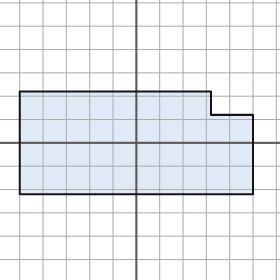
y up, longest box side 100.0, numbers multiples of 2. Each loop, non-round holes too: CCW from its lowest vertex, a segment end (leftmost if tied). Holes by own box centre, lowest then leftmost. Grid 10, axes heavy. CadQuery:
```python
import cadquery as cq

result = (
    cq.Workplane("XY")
    .moveTo(-50.0, -22.0)
    .lineTo(50.0, -22.0)
    .lineTo(50.0, 12.0)
    .lineTo(32.0, 12.0)
    .lineTo(32.0, 22.0)
    .lineTo(-50.0, 22.0)
    .close()
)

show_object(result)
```